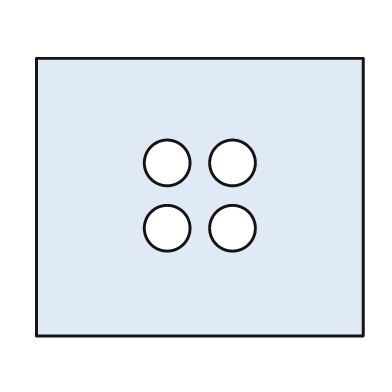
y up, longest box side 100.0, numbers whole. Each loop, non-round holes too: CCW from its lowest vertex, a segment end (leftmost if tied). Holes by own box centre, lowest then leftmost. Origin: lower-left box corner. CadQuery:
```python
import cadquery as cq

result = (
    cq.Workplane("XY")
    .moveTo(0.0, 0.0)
    .lineTo(100.0, 0.0)
    .lineTo(100.0, 85.0)
    .lineTo(0.0, 85.0)
    .close()
    .moveTo(40.0, 33.0)
    .circle(7.0)
    .moveTo(60.0, 33.0)
    .circle(7.0)
    .moveTo(40.0, 53.0)
    .circle(7.0)
    .moveTo(60.0, 53.0)
    .circle(7.0)
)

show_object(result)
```